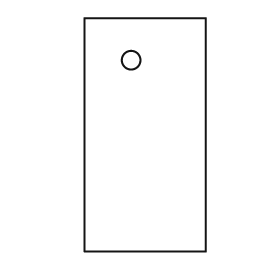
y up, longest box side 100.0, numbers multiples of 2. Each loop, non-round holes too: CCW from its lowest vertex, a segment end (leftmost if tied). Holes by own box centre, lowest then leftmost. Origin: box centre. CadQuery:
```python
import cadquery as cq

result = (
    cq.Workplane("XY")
    .moveTo(-26.0, -50.0)
    .lineTo(26.0, -50.0)
    .lineTo(26.0, 50.0)
    .lineTo(-26.0, 50.0)
    .close()
    .moveTo(-6.0, 32.0)
    .circle(4.0)
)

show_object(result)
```